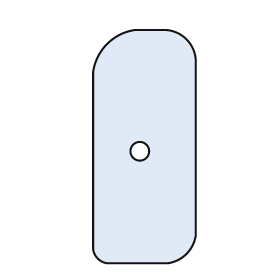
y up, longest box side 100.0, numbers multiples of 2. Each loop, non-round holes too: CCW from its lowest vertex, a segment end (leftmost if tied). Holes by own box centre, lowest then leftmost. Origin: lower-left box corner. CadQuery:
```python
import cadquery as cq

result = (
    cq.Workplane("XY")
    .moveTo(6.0, 0.0)
    .lineTo(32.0, 0.0)
    .threePointArc((40.0, 4.0), (44.0, 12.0))
    .lineTo(44.0, 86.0)
    .threePointArc((40.0, 96.0), (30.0, 100.0))
    .lineTo(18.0, 100.0)
    .threePointArc((6.0, 94.0), (0.0, 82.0))
    .lineTo(0.0, 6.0)
    .threePointArc((2.0, 2.0), (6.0, 0.0))
    .close()
    .moveTo(20.0, 48.0)
    .circle(4.0)
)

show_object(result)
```